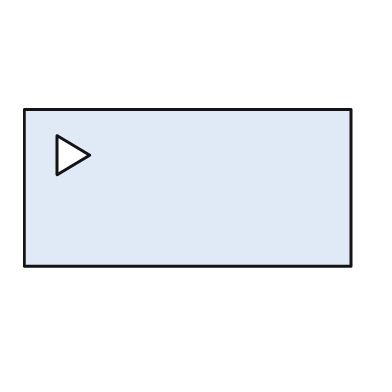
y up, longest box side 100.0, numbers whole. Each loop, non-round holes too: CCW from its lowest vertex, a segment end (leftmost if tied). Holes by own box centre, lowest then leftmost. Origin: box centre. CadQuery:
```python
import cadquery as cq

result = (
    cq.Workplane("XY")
    .moveTo(-50.0, -24.0)
    .lineTo(50.0, -24.0)
    .lineTo(50.0, 24.0)
    .lineTo(-50.0, 24.0)
    .close()
    .moveTo(-40.0, 4.0)
    .lineTo(-30.0, 10.0)
    .lineTo(-40.0, 16.0)
    .close()
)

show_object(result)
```